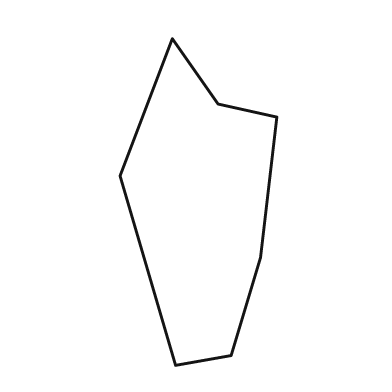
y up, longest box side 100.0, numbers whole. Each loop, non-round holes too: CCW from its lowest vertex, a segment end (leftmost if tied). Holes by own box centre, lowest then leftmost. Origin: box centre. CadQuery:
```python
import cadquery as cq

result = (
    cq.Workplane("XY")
    .moveTo(-7.0, -50.0)
    .lineTo(10.0, -47.0)
    .lineTo(19.0, -17.0)
    .lineTo(24.0, 26.0)
    .lineTo(6.0, 30.0)
    .lineTo(-8.0, 50.0)
    .lineTo(-24.0, 8.0)
    .close()
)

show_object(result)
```